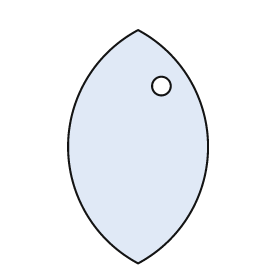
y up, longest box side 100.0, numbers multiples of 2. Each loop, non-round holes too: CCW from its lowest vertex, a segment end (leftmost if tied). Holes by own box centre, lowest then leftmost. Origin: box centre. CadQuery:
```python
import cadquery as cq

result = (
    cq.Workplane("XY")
    .moveTo(0.0, -50.0)
    .threePointArc((30.0, 0.0), (0.0, 50.0))
    .threePointArc((-30.0, 0.0), (0.0, -50.0))
    .close()
    .moveTo(10.0, 26.0)
    .circle(4.0)
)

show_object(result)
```